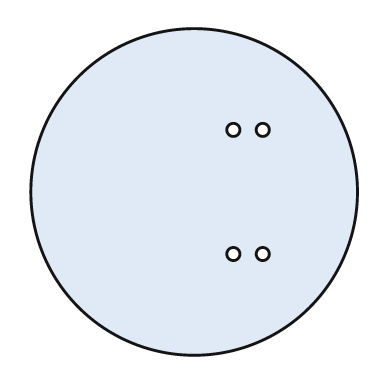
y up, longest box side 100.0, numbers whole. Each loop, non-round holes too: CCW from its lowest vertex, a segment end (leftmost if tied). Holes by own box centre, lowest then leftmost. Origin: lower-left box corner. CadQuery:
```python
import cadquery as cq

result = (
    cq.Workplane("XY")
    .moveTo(50.0, 50.0)
    .circle(50.0)
    .moveTo(62.0, 31.0)
    .circle(2.0)
    .moveTo(71.0, 31.0)
    .circle(2.0)
    .moveTo(62.0, 69.0)
    .circle(2.0)
    .moveTo(71.0, 69.0)
    .circle(2.0)
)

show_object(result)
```